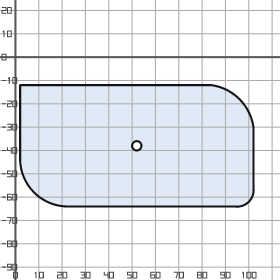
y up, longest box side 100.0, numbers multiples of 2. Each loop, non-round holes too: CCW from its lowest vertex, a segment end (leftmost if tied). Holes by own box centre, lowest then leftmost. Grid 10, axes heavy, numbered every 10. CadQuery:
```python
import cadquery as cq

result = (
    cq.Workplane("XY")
    .moveTo(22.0, -64.0)
    .lineTo(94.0, -64.0)
    .threePointArc((100.0, -62.0), (102.0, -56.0))
    .lineTo(102.0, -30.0)
    .threePointArc((96.0, -18.0), (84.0, -12.0))
    .lineTo(2.0, -12.0)
    .lineTo(2.0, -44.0)
    .threePointArc((8.0, -58.0), (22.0, -64.0))
    .close()
    .moveTo(52.0, -38.0)
    .circle(2.0)
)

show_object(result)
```